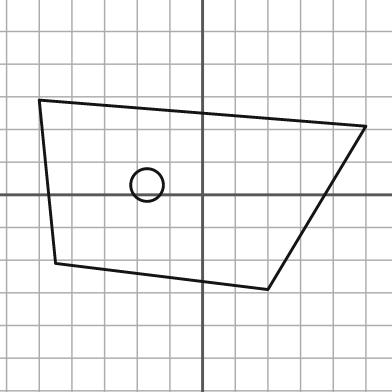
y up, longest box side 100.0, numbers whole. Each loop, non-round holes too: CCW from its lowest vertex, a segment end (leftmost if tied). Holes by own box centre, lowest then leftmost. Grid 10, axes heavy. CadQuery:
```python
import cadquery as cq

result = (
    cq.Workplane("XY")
    .moveTo(20.0, -29.0)
    .lineTo(50.0, 21.0)
    .lineTo(-50.0, 29.0)
    .lineTo(-45.0, -21.0)
    .close()
    .moveTo(-17.0, 3.0)
    .circle(5.0)
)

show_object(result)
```